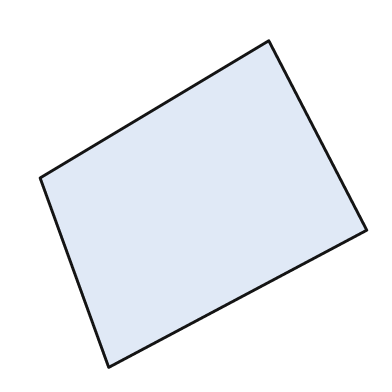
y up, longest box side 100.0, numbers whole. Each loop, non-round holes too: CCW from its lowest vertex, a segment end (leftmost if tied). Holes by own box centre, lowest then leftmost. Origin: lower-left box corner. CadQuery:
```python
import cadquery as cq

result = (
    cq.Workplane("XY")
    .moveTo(21.0, 0.0)
    .lineTo(100.0, 42.0)
    .lineTo(70.0, 100.0)
    .lineTo(0.0, 58.0)
    .close()
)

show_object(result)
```